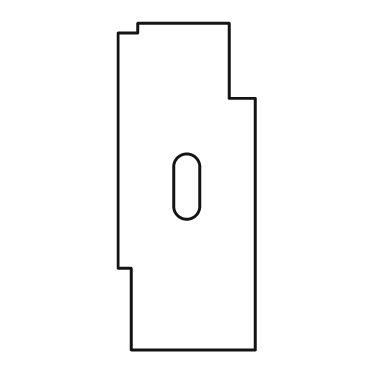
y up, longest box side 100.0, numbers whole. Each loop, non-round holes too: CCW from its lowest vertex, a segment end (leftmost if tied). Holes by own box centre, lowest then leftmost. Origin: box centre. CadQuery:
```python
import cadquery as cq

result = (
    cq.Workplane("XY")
    .moveTo(-17.0, -50.0)
    .lineTo(21.0, -50.0)
    .lineTo(21.0, 27.0)
    .lineTo(13.0, 27.0)
    .lineTo(13.0, 50.0)
    .lineTo(-15.0, 50.0)
    .lineTo(-15.0, 47.0)
    .lineTo(-21.0, 47.0)
    .lineTo(-21.0, -25.0)
    .lineTo(-17.0, -25.0)
    .close()
    .moveTo(-4.0, -6.0)
    .threePointArc((0.0, -10.0), (4.0, -6.0))
    .lineTo(4.0, 6.0)
    .threePointArc((0.0, 10.0), (-4.0, 6.0))
    .close()
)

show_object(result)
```